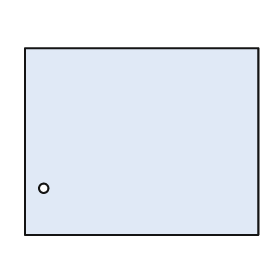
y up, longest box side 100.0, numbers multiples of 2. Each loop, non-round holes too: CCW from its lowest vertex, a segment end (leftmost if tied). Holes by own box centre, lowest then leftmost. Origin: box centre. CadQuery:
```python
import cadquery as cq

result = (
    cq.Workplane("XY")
    .moveTo(-50.0, -40.0)
    .lineTo(50.0, -40.0)
    .lineTo(50.0, 40.0)
    .lineTo(-50.0, 40.0)
    .close()
    .moveTo(-42.0, -20.0)
    .circle(2.0)
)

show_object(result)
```